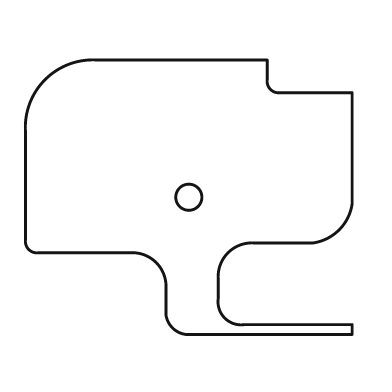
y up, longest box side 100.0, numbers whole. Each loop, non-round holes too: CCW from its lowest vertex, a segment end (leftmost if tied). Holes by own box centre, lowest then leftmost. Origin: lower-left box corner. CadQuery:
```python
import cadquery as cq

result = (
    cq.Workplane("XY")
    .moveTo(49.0, 0.0)
    .lineTo(100.0, 0.0)
    .lineTo(100.0, 3.0)
    .lineTo(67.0, 3.0)
    .threePointArc((61.0, 5.0), (59.0, 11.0))
    .lineTo(59.0, 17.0)
    .threePointArc((62.0, 25.0), (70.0, 28.0))
    .lineTo(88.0, 28.0)
    .threePointArc((96.0, 32.0), (100.0, 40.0))
    .lineTo(100.0, 74.0)
    .lineTo(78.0, 74.0)
    .threePointArc((75.0, 75.0), (74.0, 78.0))
    .lineTo(74.0, 84.0)
    .lineTo(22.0, 84.0)
    .threePointArc((6.0, 78.0), (0.0, 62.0))
    .lineTo(0.0, 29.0)
    .threePointArc((1.0, 26.0), (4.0, 25.0))
    .lineTo(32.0, 25.0)
    .threePointArc((40.0, 22.0), (43.0, 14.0))
    .lineTo(43.0, 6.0)
    .threePointArc((45.0, 2.0), (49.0, 0.0))
    .close()
    .moveTo(50.0, 42.0)
    .circle(4.0)
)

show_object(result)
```